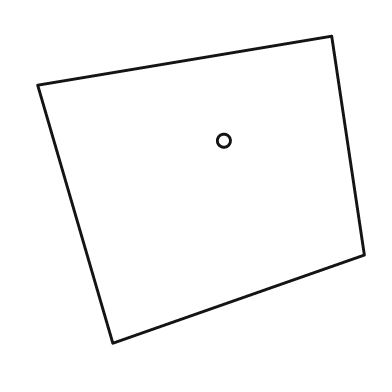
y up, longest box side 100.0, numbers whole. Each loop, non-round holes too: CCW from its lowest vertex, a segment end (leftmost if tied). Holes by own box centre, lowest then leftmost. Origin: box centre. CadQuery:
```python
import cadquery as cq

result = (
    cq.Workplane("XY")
    .moveTo(-27.0, -47.0)
    .lineTo(50.0, -20.0)
    .lineTo(40.0, 47.0)
    .lineTo(-50.0, 32.0)
    .close()
    .moveTo(7.0, 15.0)
    .circle(2.0)
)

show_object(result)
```